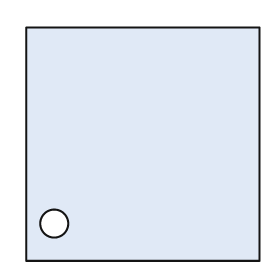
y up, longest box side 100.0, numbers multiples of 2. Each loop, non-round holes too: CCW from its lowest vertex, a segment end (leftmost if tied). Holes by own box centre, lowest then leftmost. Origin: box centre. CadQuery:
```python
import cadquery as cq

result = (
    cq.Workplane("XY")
    .moveTo(-50.0, -50.0)
    .lineTo(50.0, -50.0)
    .lineTo(50.0, 50.0)
    .lineTo(-50.0, 50.0)
    .close()
    .moveTo(-38.0, -34.0)
    .circle(6.0)
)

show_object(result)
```